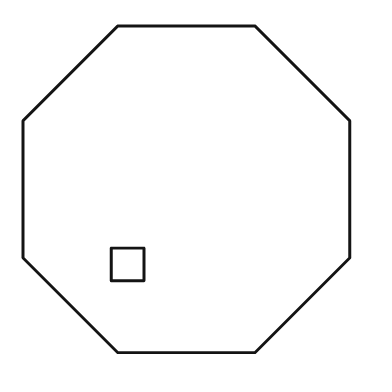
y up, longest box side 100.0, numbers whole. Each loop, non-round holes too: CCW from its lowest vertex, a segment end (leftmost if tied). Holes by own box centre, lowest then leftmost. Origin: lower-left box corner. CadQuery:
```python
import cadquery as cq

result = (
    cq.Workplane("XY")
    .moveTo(29.0, 0.0)
    .lineTo(71.0, 0.0)
    .lineTo(100.0, 29.0)
    .lineTo(100.0, 71.0)
    .lineTo(71.0, 100.0)
    .lineTo(29.0, 100.0)
    .lineTo(0.0, 71.0)
    .lineTo(0.0, 29.0)
    .close()
    .moveTo(27.0, 22.0)
    .lineTo(37.0, 22.0)
    .lineTo(37.0, 32.0)
    .lineTo(27.0, 32.0)
    .close()
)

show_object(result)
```